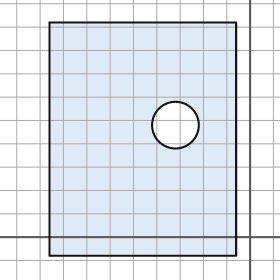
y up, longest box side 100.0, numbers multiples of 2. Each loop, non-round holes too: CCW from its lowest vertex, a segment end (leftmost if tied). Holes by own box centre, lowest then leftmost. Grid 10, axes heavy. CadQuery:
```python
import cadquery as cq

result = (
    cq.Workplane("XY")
    .moveTo(-86.0, -8.0)
    .lineTo(-6.0, -8.0)
    .lineTo(-6.0, 92.0)
    .lineTo(-86.0, 92.0)
    .close()
    .moveTo(-32.0, 48.0)
    .circle(10.0)
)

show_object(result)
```